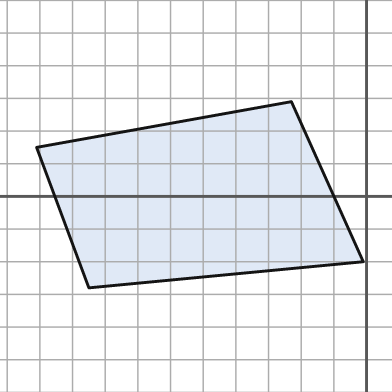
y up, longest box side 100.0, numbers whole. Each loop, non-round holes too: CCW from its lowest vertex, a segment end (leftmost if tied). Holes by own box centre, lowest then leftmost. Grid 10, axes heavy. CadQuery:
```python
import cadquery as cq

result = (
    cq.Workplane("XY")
    .moveTo(-85.0, -28.0)
    .lineTo(-1.0, -20.0)
    .lineTo(-23.0, 29.0)
    .lineTo(-101.0, 15.0)
    .close()
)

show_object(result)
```